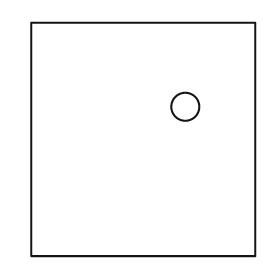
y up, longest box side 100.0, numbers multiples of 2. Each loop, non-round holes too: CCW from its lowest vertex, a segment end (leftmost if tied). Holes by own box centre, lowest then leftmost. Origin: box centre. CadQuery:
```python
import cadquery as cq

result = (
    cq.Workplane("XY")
    .moveTo(-48.0, -50.0)
    .lineTo(48.0, -50.0)
    .lineTo(48.0, 50.0)
    .lineTo(-48.0, 50.0)
    .close()
    .moveTo(18.0, 14.0)
    .circle(6.0)
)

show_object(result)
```